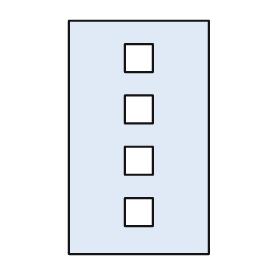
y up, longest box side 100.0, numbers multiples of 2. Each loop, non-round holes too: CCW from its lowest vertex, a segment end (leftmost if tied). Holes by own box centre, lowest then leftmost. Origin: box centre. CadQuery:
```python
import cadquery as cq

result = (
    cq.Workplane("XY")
    .moveTo(-30.0, -50.0)
    .lineTo(30.0, -50.0)
    .lineTo(30.0, 50.0)
    .lineTo(-30.0, 50.0)
    .close()
    .moveTo(-6.0, -38.0)
    .lineTo(6.0, -38.0)
    .lineTo(6.0, -26.0)
    .lineTo(-6.0, -26.0)
    .close()
    .moveTo(-6.0, -16.0)
    .lineTo(6.0, -16.0)
    .lineTo(6.0, -4.0)
    .lineTo(-6.0, -4.0)
    .close()
    .moveTo(-6.0, 6.0)
    .lineTo(6.0, 6.0)
    .lineTo(6.0, 18.0)
    .lineTo(-6.0, 18.0)
    .close()
    .moveTo(-6.0, 28.0)
    .lineTo(6.0, 28.0)
    .lineTo(6.0, 40.0)
    .lineTo(-6.0, 40.0)
    .close()
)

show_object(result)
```